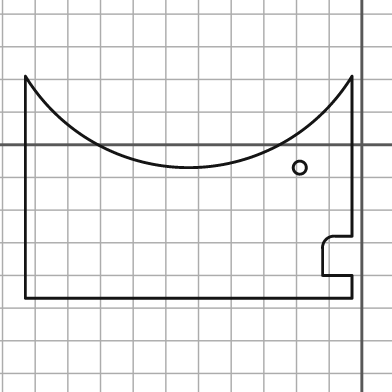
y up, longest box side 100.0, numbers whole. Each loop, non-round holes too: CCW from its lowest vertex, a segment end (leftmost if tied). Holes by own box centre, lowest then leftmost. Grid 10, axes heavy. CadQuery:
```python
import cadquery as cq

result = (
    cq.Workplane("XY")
    .moveTo(-103.0, -47.0)
    .lineTo(-3.0, -47.0)
    .lineTo(-3.0, -40.0)
    .lineTo(-12.0, -40.0)
    .lineTo(-12.0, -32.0)
    .threePointArc((-11.0, -29.0), (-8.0, -28.0))
    .lineTo(-3.0, -28.0)
    .lineTo(-3.0, 21.0)
    .threePointArc((-53.0, -7.0), (-103.0, 21.0))
    .close()
    .moveTo(-19.0, -7.0)
    .circle(2.0)
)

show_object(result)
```